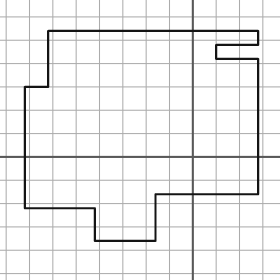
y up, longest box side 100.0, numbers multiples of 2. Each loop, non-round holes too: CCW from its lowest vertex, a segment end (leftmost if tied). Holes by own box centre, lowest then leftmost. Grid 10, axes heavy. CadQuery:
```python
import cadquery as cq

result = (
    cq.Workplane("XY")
    .moveTo(-42.0, -36.0)
    .lineTo(-16.0, -36.0)
    .lineTo(-16.0, -16.0)
    .lineTo(28.0, -16.0)
    .lineTo(28.0, 42.0)
    .lineTo(10.0, 42.0)
    .lineTo(10.0, 48.0)
    .lineTo(28.0, 48.0)
    .lineTo(28.0, 54.0)
    .lineTo(-62.0, 54.0)
    .lineTo(-62.0, 30.0)
    .lineTo(-72.0, 30.0)
    .lineTo(-72.0, -22.0)
    .lineTo(-42.0, -22.0)
    .close()
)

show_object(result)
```